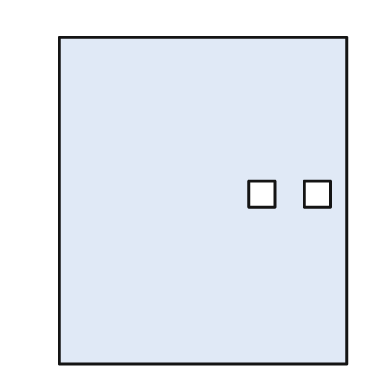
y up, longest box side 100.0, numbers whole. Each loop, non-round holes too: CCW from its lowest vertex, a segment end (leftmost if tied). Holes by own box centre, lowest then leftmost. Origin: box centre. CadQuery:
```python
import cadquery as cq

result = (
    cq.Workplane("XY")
    .moveTo(-44.0, -50.0)
    .lineTo(44.0, -50.0)
    .lineTo(44.0, 50.0)
    .lineTo(-44.0, 50.0)
    .close()
    .moveTo(14.0, -2.0)
    .lineTo(22.0, -2.0)
    .lineTo(22.0, 6.0)
    .lineTo(14.0, 6.0)
    .close()
    .moveTo(31.0, -2.0)
    .lineTo(39.0, -2.0)
    .lineTo(39.0, 6.0)
    .lineTo(31.0, 6.0)
    .close()
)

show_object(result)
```